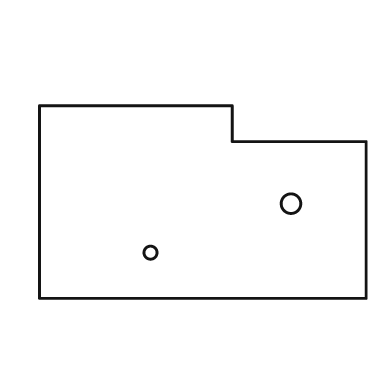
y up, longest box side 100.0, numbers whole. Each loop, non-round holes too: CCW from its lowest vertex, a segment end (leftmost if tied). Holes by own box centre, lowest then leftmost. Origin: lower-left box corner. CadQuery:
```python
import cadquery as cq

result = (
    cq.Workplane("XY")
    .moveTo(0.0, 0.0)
    .lineTo(100.0, 0.0)
    .lineTo(100.0, 48.0)
    .lineTo(59.0, 48.0)
    .lineTo(59.0, 59.0)
    .lineTo(0.0, 59.0)
    .close()
    .moveTo(34.0, 14.0)
    .circle(2.0)
    .moveTo(77.0, 29.0)
    .circle(3.0)
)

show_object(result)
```